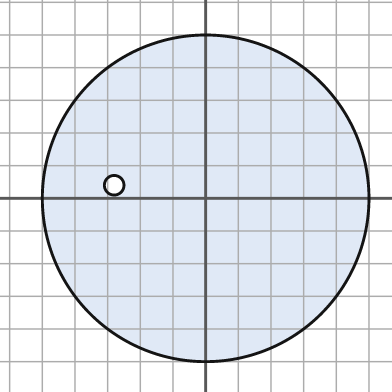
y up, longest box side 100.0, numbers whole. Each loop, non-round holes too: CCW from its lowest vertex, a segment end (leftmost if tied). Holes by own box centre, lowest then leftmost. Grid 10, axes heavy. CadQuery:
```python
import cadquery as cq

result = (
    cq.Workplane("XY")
    .moveTo(0.0, 0.0)
    .circle(50.0)
    .moveTo(-28.0, 4.0)
    .circle(3.0)
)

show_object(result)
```